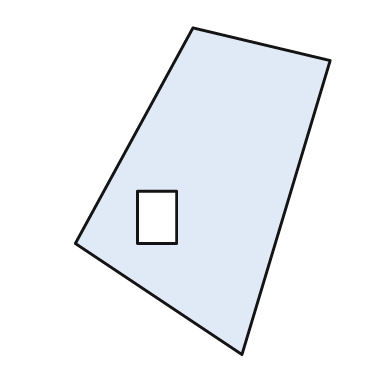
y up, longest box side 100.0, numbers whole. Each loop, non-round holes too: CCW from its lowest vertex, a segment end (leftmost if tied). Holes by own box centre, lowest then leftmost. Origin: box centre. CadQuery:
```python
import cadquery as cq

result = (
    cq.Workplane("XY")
    .moveTo(12.0, -50.0)
    .lineTo(39.0, 40.0)
    .lineTo(-3.0, 50.0)
    .lineTo(-39.0, -16.0)
    .close()
    .moveTo(-20.0, -16.0)
    .lineTo(-8.0, -16.0)
    .lineTo(-8.0, 0.0)
    .lineTo(-20.0, 0.0)
    .close()
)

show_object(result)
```